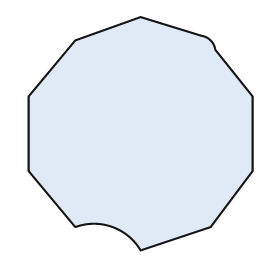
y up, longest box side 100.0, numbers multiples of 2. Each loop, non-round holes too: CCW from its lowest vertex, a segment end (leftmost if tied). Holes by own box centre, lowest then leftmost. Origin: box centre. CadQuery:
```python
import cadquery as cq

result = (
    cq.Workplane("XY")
    .moveTo(0.0, -50.0)
    .lineTo(30.0, -40.0)
    .lineTo(48.0, -16.0)
    .lineTo(48.0, 16.0)
    .lineTo(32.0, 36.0)
    .threePointArc((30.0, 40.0), (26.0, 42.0))
    .lineTo(0.0, 50.0)
    .lineTo(-28.0, 40.0)
    .lineTo(-48.0, 16.0)
    .lineTo(-48.0, -16.0)
    .lineTo(-28.0, -40.0)
    .threePointArc((-12.0, -40.0), (0.0, -50.0))
    .close()
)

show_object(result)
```